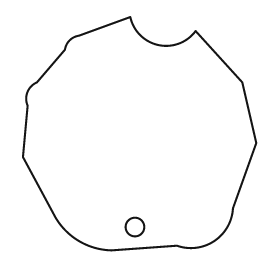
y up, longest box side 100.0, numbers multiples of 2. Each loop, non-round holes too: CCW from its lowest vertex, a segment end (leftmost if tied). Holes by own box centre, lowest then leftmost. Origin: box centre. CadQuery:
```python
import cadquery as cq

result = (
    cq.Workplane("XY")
    .moveTo(-12.0, -50.0)
    .lineTo(16.0, -48.0)
    .threePointArc((32.0, -46.0), (40.0, -32.0))
    .lineTo(50.0, -4.0)
    .lineTo(44.0, 22.0)
    .lineTo(24.0, 44.0)
    .threePointArc((8.0, 38.0), (-4.0, 50.0))
    .lineTo(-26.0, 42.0)
    .threePointArc((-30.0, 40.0), (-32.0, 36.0))
    .lineTo(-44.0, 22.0)
    .threePointArc((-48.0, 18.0), (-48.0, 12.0))
    .lineTo(-50.0, -10.0)
    .lineTo(-36.0, -36.0)
    .threePointArc((-26.0, -46.0), (-12.0, -50.0))
    .close()
    .moveTo(-2.0, -40.0)
    .circle(4.0)
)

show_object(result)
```